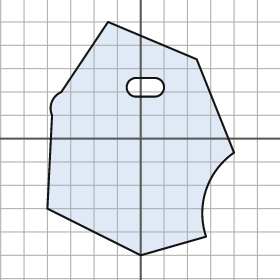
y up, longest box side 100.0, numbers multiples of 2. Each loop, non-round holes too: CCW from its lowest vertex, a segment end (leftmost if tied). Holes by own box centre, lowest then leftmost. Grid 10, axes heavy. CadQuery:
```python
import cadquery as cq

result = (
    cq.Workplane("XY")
    .moveTo(0.0, -50.0)
    .lineTo(28.0, -42.0)
    .threePointArc((28.0, -22.0), (40.0, -6.0))
    .lineTo(24.0, 34.0)
    .lineTo(-14.0, 50.0)
    .lineTo(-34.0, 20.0)
    .threePointArc((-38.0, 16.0), (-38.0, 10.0))
    .lineTo(-40.0, -30.0)
    .close()
    .moveTo(-2.0, 18.0)
    .lineTo(6.0, 18.0)
    .threePointArc((10.0, 22.0), (6.0, 26.0))
    .lineTo(-2.0, 26.0)
    .threePointArc((-6.0, 22.0), (-2.0, 18.0))
    .close()
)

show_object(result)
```